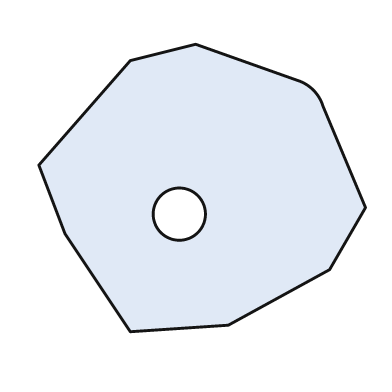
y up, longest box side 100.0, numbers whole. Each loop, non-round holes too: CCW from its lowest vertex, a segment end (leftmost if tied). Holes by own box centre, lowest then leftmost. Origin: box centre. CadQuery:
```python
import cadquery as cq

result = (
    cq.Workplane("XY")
    .moveTo(-22.0, -44.0)
    .lineTo(8.0, -42.0)
    .lineTo(39.0, -25.0)
    .lineTo(50.0, -6.0)
    .lineTo(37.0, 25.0)
    .threePointArc((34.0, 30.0), (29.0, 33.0))
    .lineTo(-2.0, 44.0)
    .lineTo(-22.0, 39.0)
    .lineTo(-50.0, 7.0)
    .lineTo(-42.0, -14.0)
    .close()
    .moveTo(-7.0, -8.0)
    .circle(8.0)
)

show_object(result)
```